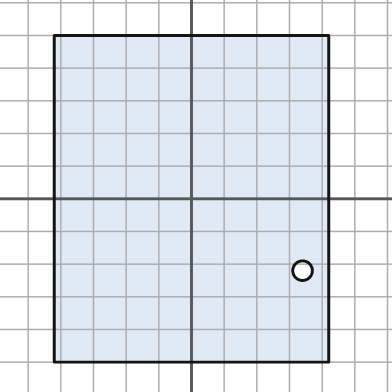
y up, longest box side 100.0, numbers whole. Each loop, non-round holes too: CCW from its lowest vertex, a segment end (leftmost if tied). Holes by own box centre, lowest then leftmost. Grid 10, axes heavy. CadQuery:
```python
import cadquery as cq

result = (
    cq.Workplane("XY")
    .moveTo(-42.0, -50.0)
    .lineTo(42.0, -50.0)
    .lineTo(42.0, 50.0)
    .lineTo(-42.0, 50.0)
    .close()
    .moveTo(34.0, -22.0)
    .circle(3.0)
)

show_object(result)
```